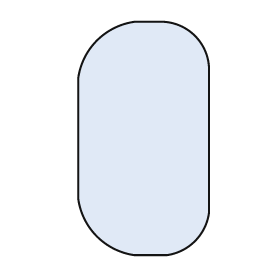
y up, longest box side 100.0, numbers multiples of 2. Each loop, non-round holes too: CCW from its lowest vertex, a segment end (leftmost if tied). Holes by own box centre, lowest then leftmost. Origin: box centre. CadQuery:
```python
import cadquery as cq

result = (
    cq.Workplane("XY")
    .moveTo(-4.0, -50.0)
    .lineTo(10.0, -50.0)
    .threePointArc((22.0, -44.0), (28.0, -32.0))
    .lineTo(28.0, 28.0)
    .threePointArc((22.0, 44.0), (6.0, 50.0))
    .lineTo(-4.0, 50.0)
    .threePointArc((-20.0, 42.0), (-28.0, 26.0))
    .lineTo(-28.0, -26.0)
    .threePointArc((-20.0, -42.0), (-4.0, -50.0))
    .close()
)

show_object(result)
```